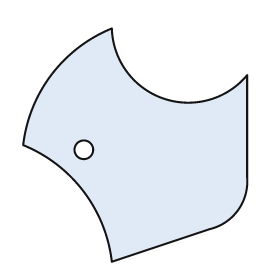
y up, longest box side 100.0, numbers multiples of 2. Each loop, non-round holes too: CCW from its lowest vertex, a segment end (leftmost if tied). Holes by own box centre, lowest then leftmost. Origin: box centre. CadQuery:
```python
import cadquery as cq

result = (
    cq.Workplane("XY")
    .moveTo(-10.0, -50.0)
    .lineTo(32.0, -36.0)
    .threePointArc((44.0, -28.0), (48.0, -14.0))
    .lineTo(48.0, 30.0)
    .threePointArc((12.0, 20.0), (-10.0, 50.0))
    .threePointArc((-36.0, 30.0), (-48.0, 0.0))
    .threePointArc((-22.0, -20.0), (-10.0, -50.0))
    .close()
    .moveTo(-22.0, -2.0)
    .circle(4.0)
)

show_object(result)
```